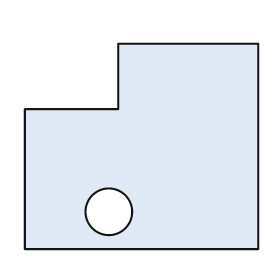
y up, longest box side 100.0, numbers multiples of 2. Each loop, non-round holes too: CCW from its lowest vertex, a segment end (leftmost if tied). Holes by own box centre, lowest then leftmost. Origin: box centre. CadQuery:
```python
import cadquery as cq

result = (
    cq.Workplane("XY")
    .moveTo(-50.0, -44.0)
    .lineTo(50.0, -44.0)
    .lineTo(50.0, 44.0)
    .lineTo(-10.0, 44.0)
    .lineTo(-10.0, 16.0)
    .lineTo(-50.0, 16.0)
    .close()
    .moveTo(-14.0, -28.0)
    .circle(10.0)
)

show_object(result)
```